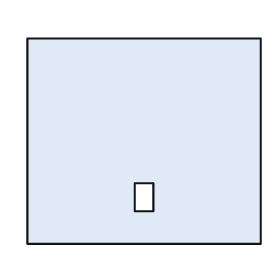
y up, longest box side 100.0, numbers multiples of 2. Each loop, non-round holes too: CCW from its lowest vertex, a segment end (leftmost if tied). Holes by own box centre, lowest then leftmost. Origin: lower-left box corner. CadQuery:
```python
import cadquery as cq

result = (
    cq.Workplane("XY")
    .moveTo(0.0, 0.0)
    .lineTo(100.0, 0.0)
    .lineTo(100.0, 88.0)
    .lineTo(0.0, 88.0)
    .close()
    .moveTo(46.0, 14.0)
    .lineTo(54.0, 14.0)
    .lineTo(54.0, 26.0)
    .lineTo(46.0, 26.0)
    .close()
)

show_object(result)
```